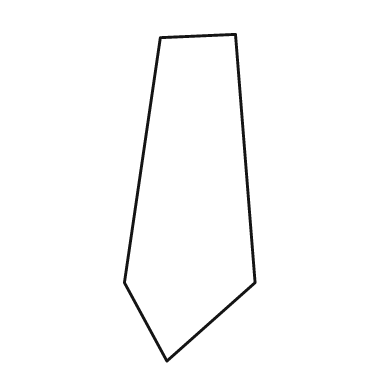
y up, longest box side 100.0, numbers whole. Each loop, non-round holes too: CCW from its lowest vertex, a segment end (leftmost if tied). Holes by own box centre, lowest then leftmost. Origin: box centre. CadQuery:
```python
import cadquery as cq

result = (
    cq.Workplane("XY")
    .moveTo(-7.0, -50.0)
    .lineTo(20.0, -26.0)
    .lineTo(14.0, 50.0)
    .lineTo(-9.0, 49.0)
    .lineTo(-20.0, -26.0)
    .close()
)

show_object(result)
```